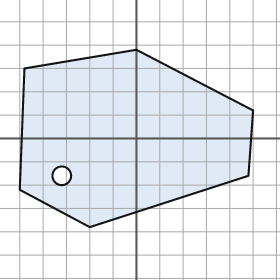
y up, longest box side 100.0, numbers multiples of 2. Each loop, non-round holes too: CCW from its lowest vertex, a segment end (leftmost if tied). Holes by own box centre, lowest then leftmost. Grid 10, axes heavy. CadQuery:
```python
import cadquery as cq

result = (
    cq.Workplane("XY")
    .moveTo(-20.0, -38.0)
    .lineTo(48.0, -16.0)
    .lineTo(50.0, 12.0)
    .lineTo(0.0, 38.0)
    .lineTo(-48.0, 30.0)
    .lineTo(-50.0, -22.0)
    .close()
    .moveTo(-32.0, -16.0)
    .circle(4.0)
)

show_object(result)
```